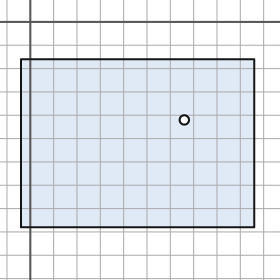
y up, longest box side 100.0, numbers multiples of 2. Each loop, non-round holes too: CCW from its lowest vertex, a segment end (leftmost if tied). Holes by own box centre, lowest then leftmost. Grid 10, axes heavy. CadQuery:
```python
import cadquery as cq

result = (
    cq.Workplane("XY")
    .moveTo(-4.0, -88.0)
    .lineTo(96.0, -88.0)
    .lineTo(96.0, -16.0)
    .lineTo(-4.0, -16.0)
    .close()
    .moveTo(66.0, -42.0)
    .circle(2.0)
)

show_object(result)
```